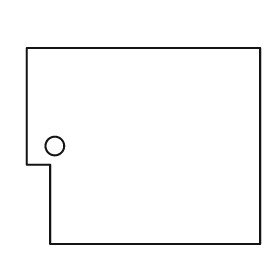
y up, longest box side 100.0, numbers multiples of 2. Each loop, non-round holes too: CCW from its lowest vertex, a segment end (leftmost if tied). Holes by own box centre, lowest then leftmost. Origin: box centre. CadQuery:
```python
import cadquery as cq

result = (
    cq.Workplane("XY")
    .moveTo(-40.0, -42.0)
    .lineTo(50.0, -42.0)
    .lineTo(50.0, 42.0)
    .lineTo(-50.0, 42.0)
    .lineTo(-50.0, -8.0)
    .lineTo(-40.0, -8.0)
    .close()
    .moveTo(-38.0, 0.0)
    .circle(4.0)
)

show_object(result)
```